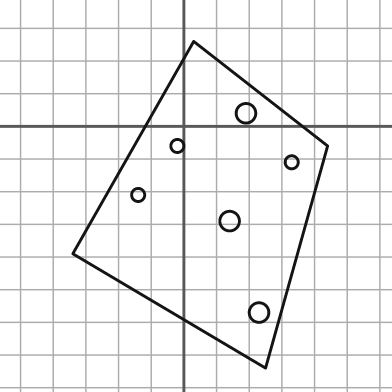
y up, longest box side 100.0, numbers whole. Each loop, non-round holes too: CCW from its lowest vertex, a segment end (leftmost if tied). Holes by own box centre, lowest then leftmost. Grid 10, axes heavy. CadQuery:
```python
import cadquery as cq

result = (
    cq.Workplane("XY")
    .moveTo(25.0, -74.0)
    .lineTo(44.0, -6.0)
    .lineTo(3.0, 26.0)
    .lineTo(-34.0, -39.0)
    .close()
    .moveTo(23.0, -57.0)
    .circle(3.0)
    .moveTo(14.0, -29.0)
    .circle(3.0)
    .moveTo(-14.0, -21.0)
    .circle(2.0)
    .moveTo(33.0, -11.0)
    .circle(2.0)
    .moveTo(-2.0, -6.0)
    .circle(2.0)
    .moveTo(19.0, 4.0)
    .circle(3.0)
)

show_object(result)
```